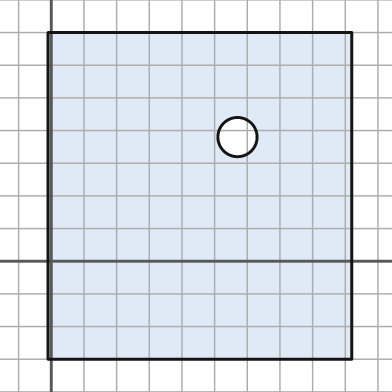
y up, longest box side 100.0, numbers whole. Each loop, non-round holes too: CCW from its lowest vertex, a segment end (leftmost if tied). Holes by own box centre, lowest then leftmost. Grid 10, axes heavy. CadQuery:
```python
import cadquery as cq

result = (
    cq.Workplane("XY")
    .moveTo(-1.0, -30.0)
    .lineTo(92.0, -30.0)
    .lineTo(92.0, 70.0)
    .lineTo(-1.0, 70.0)
    .close()
    .moveTo(57.0, 38.0)
    .circle(6.0)
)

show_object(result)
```